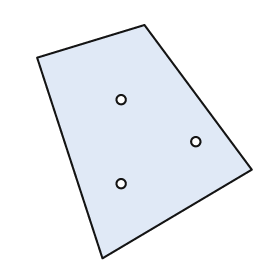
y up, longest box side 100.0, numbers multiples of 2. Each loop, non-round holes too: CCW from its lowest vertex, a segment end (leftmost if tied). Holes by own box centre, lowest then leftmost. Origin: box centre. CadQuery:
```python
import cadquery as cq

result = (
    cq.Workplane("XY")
    .moveTo(-18.0, -50.0)
    .lineTo(46.0, -12.0)
    .lineTo(0.0, 50.0)
    .lineTo(-46.0, 36.0)
    .close()
    .moveTo(-10.0, -18.0)
    .circle(2.0)
    .moveTo(22.0, 0.0)
    .circle(2.0)
    .moveTo(-10.0, 18.0)
    .circle(2.0)
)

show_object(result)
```